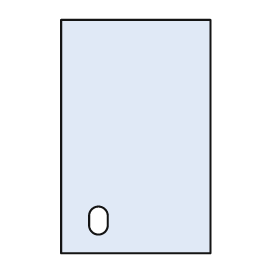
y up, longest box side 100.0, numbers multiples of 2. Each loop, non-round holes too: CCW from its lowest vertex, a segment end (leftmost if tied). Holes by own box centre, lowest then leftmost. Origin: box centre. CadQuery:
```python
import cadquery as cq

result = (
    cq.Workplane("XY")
    .moveTo(-32.0, -50.0)
    .lineTo(32.0, -50.0)
    .lineTo(32.0, 50.0)
    .lineTo(-32.0, 50.0)
    .close()
    .moveTo(-20.0, -38.0)
    .threePointArc((-16.0, -42.0), (-12.0, -38.0))
    .lineTo(-12.0, -34.0)
    .threePointArc((-16.0, -30.0), (-20.0, -34.0))
    .close()
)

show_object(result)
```